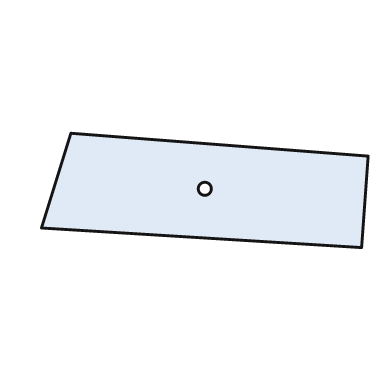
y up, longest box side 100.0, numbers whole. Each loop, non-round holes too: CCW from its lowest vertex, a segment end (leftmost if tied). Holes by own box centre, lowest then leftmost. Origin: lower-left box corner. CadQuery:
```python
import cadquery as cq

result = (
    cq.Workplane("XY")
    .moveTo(98.0, 0.0)
    .lineTo(100.0, 28.0)
    .lineTo(9.0, 35.0)
    .lineTo(0.0, 6.0)
    .close()
    .moveTo(50.0, 18.0)
    .circle(2.0)
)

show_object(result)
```